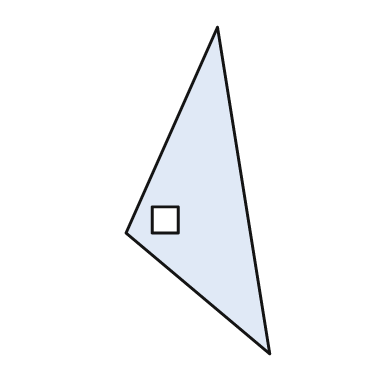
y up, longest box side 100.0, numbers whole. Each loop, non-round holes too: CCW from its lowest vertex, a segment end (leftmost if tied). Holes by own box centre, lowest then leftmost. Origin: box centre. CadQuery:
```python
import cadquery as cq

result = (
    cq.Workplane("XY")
    .moveTo(22.0, -50.0)
    .lineTo(6.0, 50.0)
    .lineTo(-22.0, -13.0)
    .close()
    .moveTo(-14.0, -13.0)
    .lineTo(-6.0, -13.0)
    .lineTo(-6.0, -5.0)
    .lineTo(-14.0, -5.0)
    .close()
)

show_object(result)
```